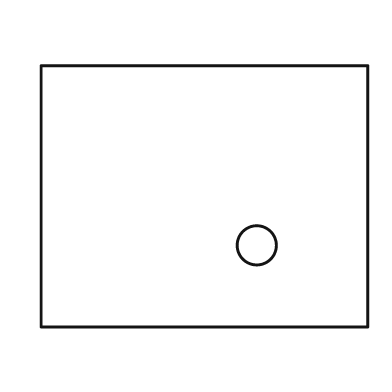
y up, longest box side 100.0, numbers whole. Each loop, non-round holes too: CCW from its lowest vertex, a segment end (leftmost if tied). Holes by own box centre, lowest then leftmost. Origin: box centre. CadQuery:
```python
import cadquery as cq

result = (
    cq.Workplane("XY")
    .moveTo(-50.0, -40.0)
    .lineTo(50.0, -40.0)
    .lineTo(50.0, 40.0)
    .lineTo(-50.0, 40.0)
    .close()
    .moveTo(16.0, -15.0)
    .circle(6.0)
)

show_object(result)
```